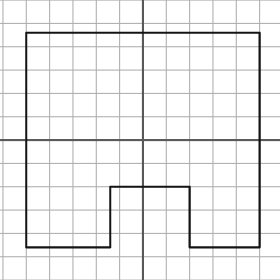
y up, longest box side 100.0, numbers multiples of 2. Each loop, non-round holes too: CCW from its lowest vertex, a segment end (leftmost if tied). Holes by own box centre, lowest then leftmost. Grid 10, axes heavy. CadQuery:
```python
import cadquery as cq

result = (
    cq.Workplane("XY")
    .moveTo(-50.0, -46.0)
    .lineTo(-14.0, -46.0)
    .lineTo(-14.0, -20.0)
    .lineTo(20.0, -20.0)
    .lineTo(20.0, -46.0)
    .lineTo(50.0, -46.0)
    .lineTo(50.0, 46.0)
    .lineTo(-50.0, 46.0)
    .close()
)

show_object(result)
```